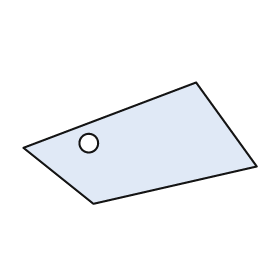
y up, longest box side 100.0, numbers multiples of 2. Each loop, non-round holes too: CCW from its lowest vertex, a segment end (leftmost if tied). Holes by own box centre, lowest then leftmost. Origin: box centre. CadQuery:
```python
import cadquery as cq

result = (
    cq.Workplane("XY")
    .moveTo(-20.0, -26.0)
    .lineTo(50.0, -10.0)
    .lineTo(24.0, 26.0)
    .lineTo(-50.0, -2.0)
    .close()
    .moveTo(-22.0, 0.0)
    .circle(4.0)
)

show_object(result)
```